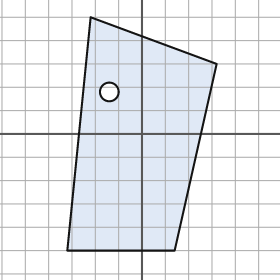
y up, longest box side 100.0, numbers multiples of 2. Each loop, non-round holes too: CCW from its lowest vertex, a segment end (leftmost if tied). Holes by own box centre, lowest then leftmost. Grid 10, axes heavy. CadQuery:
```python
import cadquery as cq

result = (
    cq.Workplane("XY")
    .moveTo(-32.0, -50.0)
    .lineTo(14.0, -50.0)
    .lineTo(32.0, 30.0)
    .lineTo(-22.0, 50.0)
    .close()
    .moveTo(-14.0, 18.0)
    .circle(4.0)
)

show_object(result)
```